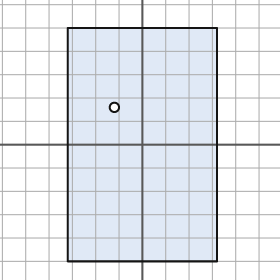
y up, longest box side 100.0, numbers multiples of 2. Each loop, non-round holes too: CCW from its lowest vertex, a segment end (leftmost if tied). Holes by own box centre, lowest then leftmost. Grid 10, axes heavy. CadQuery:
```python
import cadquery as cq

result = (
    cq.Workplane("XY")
    .moveTo(-32.0, -50.0)
    .lineTo(32.0, -50.0)
    .lineTo(32.0, 50.0)
    .lineTo(-32.0, 50.0)
    .close()
    .moveTo(-12.0, 16.0)
    .circle(2.0)
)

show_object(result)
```